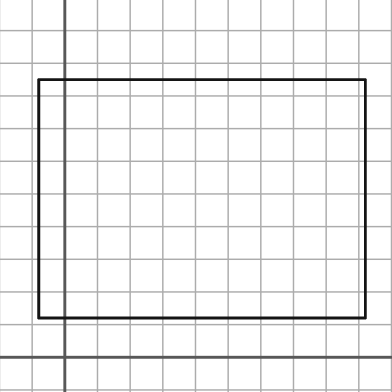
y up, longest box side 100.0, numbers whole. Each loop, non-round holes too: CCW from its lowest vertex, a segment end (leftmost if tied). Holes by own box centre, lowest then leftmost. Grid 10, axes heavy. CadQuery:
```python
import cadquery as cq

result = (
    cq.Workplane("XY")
    .moveTo(-8.0, 12.0)
    .lineTo(92.0, 12.0)
    .lineTo(92.0, 85.0)
    .lineTo(-8.0, 85.0)
    .close()
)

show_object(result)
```